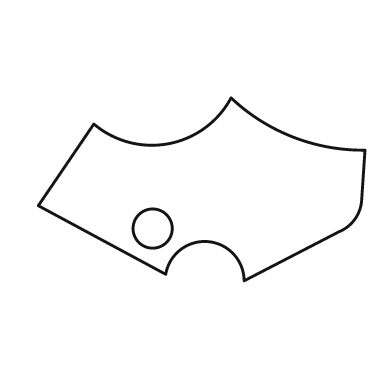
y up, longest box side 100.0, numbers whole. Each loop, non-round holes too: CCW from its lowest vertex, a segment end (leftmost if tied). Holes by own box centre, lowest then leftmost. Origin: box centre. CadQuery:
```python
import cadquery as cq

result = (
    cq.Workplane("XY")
    .moveTo(13.0, -28.0)
    .lineTo(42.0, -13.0)
    .threePointArc((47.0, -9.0), (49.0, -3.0))
    .lineTo(50.0, 12.0)
    .threePointArc((28.0, 16.0), (9.0, 28.0))
    .threePointArc((-10.0, 14.0), (-33.0, 20.0))
    .lineTo(-50.0, -5.0)
    .lineTo(-11.0, -26.0)
    .threePointArc((2.0, -16.0), (13.0, -28.0))
    .close()
    .moveTo(-15.0, -12.0)
    .circle(6.0)
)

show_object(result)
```